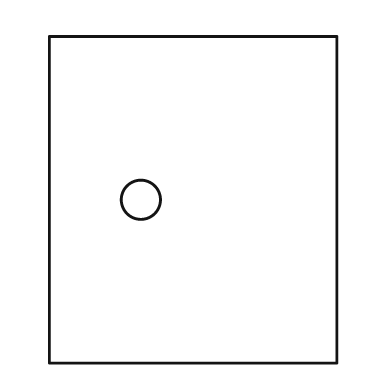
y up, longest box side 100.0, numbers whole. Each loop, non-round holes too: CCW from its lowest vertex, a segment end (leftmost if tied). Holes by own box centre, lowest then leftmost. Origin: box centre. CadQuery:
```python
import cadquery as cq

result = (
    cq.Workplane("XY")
    .moveTo(-44.0, -50.0)
    .lineTo(44.0, -50.0)
    .lineTo(44.0, 50.0)
    .lineTo(-44.0, 50.0)
    .close()
    .moveTo(-16.0, 0.0)
    .circle(6.0)
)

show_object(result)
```